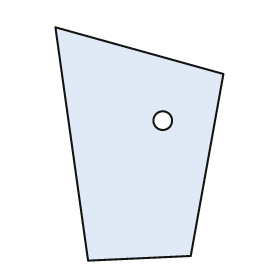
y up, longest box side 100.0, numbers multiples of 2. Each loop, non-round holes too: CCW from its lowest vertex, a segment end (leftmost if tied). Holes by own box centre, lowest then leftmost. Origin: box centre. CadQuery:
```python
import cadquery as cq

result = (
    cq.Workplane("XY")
    .moveTo(-22.0, -50.0)
    .lineTo(22.0, -48.0)
    .lineTo(36.0, 30.0)
    .lineTo(-36.0, 50.0)
    .close()
    .moveTo(10.0, 10.0)
    .circle(4.0)
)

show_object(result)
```